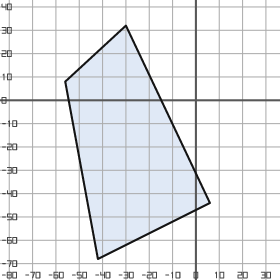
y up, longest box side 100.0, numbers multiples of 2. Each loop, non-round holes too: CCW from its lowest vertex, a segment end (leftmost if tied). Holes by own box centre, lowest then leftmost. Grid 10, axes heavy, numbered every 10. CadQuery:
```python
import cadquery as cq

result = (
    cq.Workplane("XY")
    .moveTo(-42.0, -68.0)
    .lineTo(6.0, -44.0)
    .lineTo(-30.0, 32.0)
    .lineTo(-56.0, 8.0)
    .close()
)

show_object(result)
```